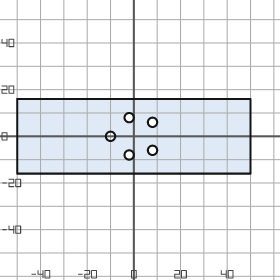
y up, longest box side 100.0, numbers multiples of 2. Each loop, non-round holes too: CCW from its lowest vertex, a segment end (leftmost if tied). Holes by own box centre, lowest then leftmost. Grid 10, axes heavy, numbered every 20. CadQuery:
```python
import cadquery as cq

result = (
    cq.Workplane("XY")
    .moveTo(-50.0, -16.0)
    .lineTo(50.0, -16.0)
    .lineTo(50.0, 16.0)
    .lineTo(-50.0, 16.0)
    .close()
    .moveTo(-2.0, -8.0)
    .circle(2.0)
    .moveTo(8.0, -6.0)
    .circle(2.0)
    .moveTo(-10.0, 0.0)
    .circle(2.0)
    .moveTo(8.0, 6.0)
    .circle(2.0)
    .moveTo(-2.0, 8.0)
    .circle(2.0)
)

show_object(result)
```